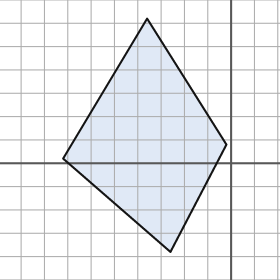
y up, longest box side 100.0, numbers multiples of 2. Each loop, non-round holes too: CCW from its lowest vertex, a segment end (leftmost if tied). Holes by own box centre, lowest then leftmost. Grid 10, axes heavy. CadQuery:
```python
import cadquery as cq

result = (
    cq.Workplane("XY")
    .moveTo(-26.0, -38.0)
    .lineTo(-2.0, 8.0)
    .lineTo(-36.0, 62.0)
    .lineTo(-72.0, 2.0)
    .close()
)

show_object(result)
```